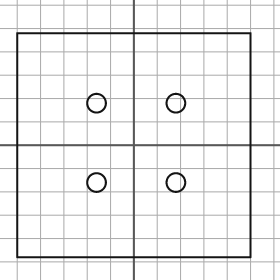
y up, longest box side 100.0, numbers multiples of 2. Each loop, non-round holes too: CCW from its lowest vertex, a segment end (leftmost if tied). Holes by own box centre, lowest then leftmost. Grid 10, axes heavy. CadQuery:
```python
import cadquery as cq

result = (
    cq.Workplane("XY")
    .moveTo(-50.0, -48.0)
    .lineTo(50.0, -48.0)
    .lineTo(50.0, 48.0)
    .lineTo(-50.0, 48.0)
    .close()
    .moveTo(-16.0, -16.0)
    .circle(4.0)
    .moveTo(18.0, -16.0)
    .circle(4.0)
    .moveTo(-16.0, 18.0)
    .circle(4.0)
    .moveTo(18.0, 18.0)
    .circle(4.0)
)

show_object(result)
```